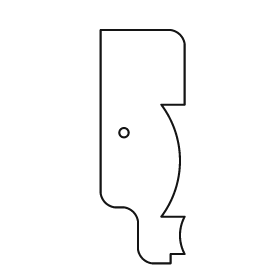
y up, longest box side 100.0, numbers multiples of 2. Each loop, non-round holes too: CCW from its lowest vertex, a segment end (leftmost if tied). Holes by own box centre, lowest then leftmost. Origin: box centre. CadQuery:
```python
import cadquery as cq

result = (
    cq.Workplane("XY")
    .moveTo(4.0, -50.0)
    .lineTo(12.0, -50.0)
    .lineTo(12.0, -46.0)
    .lineTo(18.0, -46.0)
    .threePointArc((16.0, -38.0), (18.0, -30.0))
    .lineTo(8.0, -30.0)
    .threePointArc((16.0, -6.0), (8.0, 18.0))
    .lineTo(18.0, 18.0)
    .lineTo(18.0, 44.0)
    .threePointArc((16.0, 48.0), (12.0, 50.0))
    .lineTo(-18.0, 50.0)
    .lineTo(-18.0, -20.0)
    .threePointArc((-16.0, -24.0), (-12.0, -26.0))
    .lineTo(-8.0, -26.0)
    .threePointArc((-4.0, -28.0), (-2.0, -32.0))
    .lineTo(-2.0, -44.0)
    .threePointArc((0.0, -48.0), (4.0, -50.0))
    .close()
    .moveTo(-8.0, 6.0)
    .circle(2.0)
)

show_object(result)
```